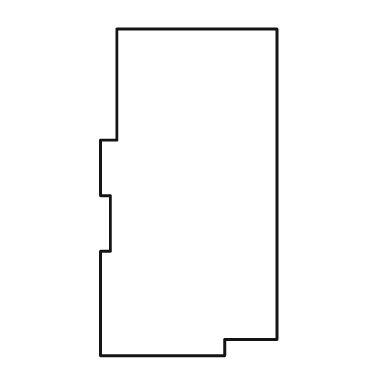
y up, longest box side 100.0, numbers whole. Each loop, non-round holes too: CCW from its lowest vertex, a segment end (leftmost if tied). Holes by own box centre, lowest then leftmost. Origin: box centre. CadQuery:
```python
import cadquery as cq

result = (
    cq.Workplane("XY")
    .moveTo(-27.0, -50.0)
    .lineTo(11.0, -50.0)
    .lineTo(11.0, -45.0)
    .lineTo(27.0, -45.0)
    .lineTo(27.0, 50.0)
    .lineTo(-22.0, 50.0)
    .lineTo(-22.0, 16.0)
    .lineTo(-27.0, 16.0)
    .lineTo(-27.0, -1.0)
    .lineTo(-24.0, -1.0)
    .lineTo(-24.0, -18.0)
    .lineTo(-27.0, -18.0)
    .close()
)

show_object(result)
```